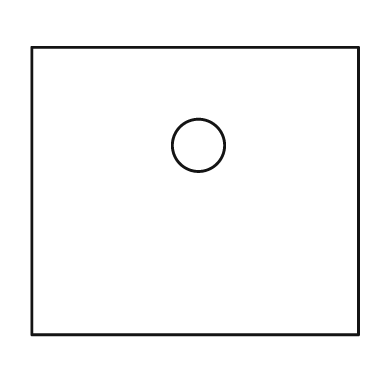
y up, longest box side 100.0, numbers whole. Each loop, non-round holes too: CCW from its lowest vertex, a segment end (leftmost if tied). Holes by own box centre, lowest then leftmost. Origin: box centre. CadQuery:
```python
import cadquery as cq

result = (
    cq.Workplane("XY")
    .moveTo(-50.0, -44.0)
    .lineTo(50.0, -44.0)
    .lineTo(50.0, 44.0)
    .lineTo(-50.0, 44.0)
    .close()
    .moveTo(1.0, 14.0)
    .circle(8.0)
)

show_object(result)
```